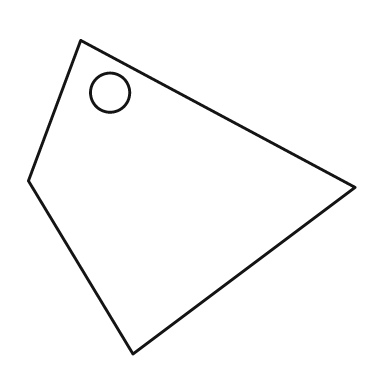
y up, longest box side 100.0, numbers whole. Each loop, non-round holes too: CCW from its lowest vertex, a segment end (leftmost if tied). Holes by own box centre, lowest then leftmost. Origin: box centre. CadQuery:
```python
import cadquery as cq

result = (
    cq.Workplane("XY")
    .moveTo(-18.0, -48.0)
    .lineTo(50.0, 3.0)
    .lineTo(-34.0, 48.0)
    .lineTo(-50.0, 5.0)
    .close()
    .moveTo(-25.0, 32.0)
    .circle(6.0)
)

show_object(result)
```